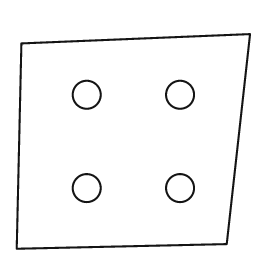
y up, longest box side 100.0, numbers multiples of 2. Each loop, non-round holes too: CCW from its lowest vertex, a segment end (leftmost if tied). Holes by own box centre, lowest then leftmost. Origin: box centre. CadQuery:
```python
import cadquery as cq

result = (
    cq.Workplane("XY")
    .moveTo(-50.0, -46.0)
    .lineTo(40.0, -44.0)
    .lineTo(50.0, 46.0)
    .lineTo(-48.0, 42.0)
    .close()
    .moveTo(-20.0, -20.0)
    .circle(6.0)
    .moveTo(20.0, -20.0)
    .circle(6.0)
    .moveTo(-20.0, 20.0)
    .circle(6.0)
    .moveTo(20.0, 20.0)
    .circle(6.0)
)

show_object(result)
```